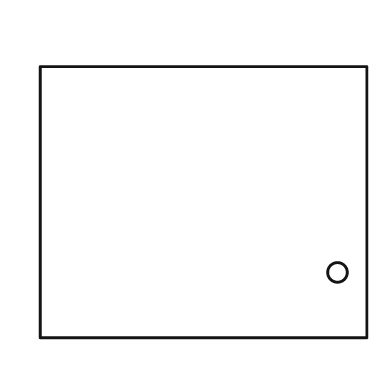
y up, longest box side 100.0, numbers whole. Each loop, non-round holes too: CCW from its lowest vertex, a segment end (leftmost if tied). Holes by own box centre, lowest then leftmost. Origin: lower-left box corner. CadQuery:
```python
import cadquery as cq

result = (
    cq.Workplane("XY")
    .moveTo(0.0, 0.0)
    .lineTo(100.0, 0.0)
    .lineTo(100.0, 83.0)
    .lineTo(0.0, 83.0)
    .close()
    .moveTo(91.0, 20.0)
    .circle(3.0)
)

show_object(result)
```